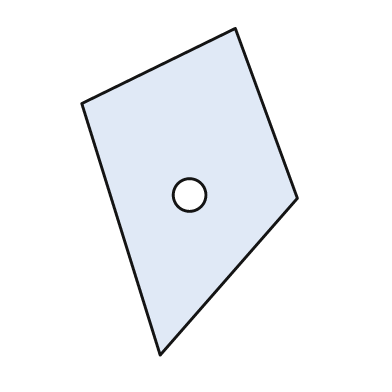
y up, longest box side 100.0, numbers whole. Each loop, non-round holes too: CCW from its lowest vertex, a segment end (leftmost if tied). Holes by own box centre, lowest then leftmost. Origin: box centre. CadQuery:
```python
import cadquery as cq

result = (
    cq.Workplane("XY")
    .moveTo(-9.0, -50.0)
    .lineTo(33.0, -2.0)
    .lineTo(14.0, 50.0)
    .lineTo(-33.0, 27.0)
    .close()
    .moveTo(0.0, -1.0)
    .circle(5.0)
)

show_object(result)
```